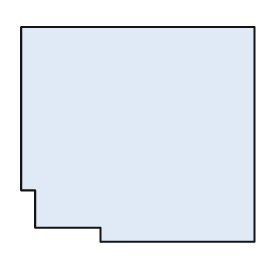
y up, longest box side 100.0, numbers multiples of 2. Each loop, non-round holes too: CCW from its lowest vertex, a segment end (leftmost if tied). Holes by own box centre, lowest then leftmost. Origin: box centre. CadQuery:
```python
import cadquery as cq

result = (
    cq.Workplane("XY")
    .moveTo(-16.0, -46.0)
    .lineTo(50.0, -46.0)
    .lineTo(50.0, 46.0)
    .lineTo(-50.0, 46.0)
    .lineTo(-50.0, -24.0)
    .lineTo(-44.0, -24.0)
    .lineTo(-44.0, -40.0)
    .lineTo(-16.0, -40.0)
    .close()
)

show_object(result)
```